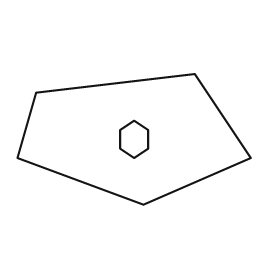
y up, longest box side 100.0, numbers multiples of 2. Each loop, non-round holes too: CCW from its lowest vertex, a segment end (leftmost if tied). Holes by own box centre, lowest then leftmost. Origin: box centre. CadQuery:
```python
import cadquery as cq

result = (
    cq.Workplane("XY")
    .moveTo(4.0, -28.0)
    .lineTo(50.0, -8.0)
    .lineTo(26.0, 28.0)
    .lineTo(-42.0, 20.0)
    .lineTo(-50.0, -8.0)
    .close()
    .moveTo(0.0, -8.0)
    .lineTo(6.0, -4.0)
    .lineTo(6.0, 4.0)
    .lineTo(0.0, 8.0)
    .lineTo(-6.0, 4.0)
    .lineTo(-6.0, -4.0)
    .close()
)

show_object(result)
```